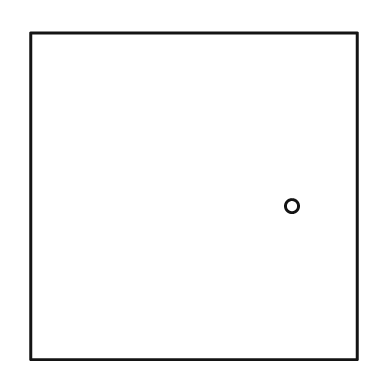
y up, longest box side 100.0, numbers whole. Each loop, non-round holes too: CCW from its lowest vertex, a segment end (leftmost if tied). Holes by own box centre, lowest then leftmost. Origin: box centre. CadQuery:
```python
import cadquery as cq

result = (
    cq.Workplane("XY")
    .moveTo(-50.0, -50.0)
    .lineTo(50.0, -50.0)
    .lineTo(50.0, 50.0)
    .lineTo(-50.0, 50.0)
    .close()
    .moveTo(30.0, -3.0)
    .circle(2.0)
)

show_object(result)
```